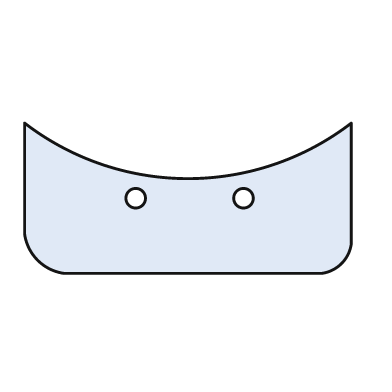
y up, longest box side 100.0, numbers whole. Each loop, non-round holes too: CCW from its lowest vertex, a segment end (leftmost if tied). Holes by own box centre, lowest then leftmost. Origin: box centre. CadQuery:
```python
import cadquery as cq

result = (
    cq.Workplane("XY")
    .moveTo(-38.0, -23.0)
    .lineTo(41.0, -23.0)
    .threePointArc((47.0, -20.0), (50.0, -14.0))
    .lineTo(50.0, 23.0)
    .threePointArc((0.0, 6.0), (-50.0, 23.0))
    .lineTo(-50.0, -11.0)
    .threePointArc((-46.0, -19.0), (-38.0, -23.0))
    .close()
    .moveTo(-16.0, 0.0)
    .circle(3.0)
    .moveTo(17.0, 0.0)
    .circle(3.0)
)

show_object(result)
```